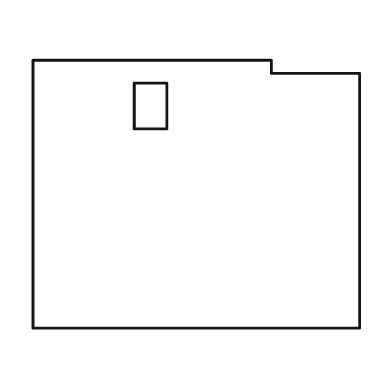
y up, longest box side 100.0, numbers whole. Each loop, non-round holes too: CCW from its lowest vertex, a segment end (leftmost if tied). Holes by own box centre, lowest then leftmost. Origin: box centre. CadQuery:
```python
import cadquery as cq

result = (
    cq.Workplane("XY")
    .moveTo(-50.0, -41.0)
    .lineTo(50.0, -41.0)
    .lineTo(50.0, 37.0)
    .lineTo(23.0, 37.0)
    .lineTo(23.0, 41.0)
    .lineTo(-50.0, 41.0)
    .close()
    .moveTo(-19.0, 20.0)
    .lineTo(-9.0, 20.0)
    .lineTo(-9.0, 34.0)
    .lineTo(-19.0, 34.0)
    .close()
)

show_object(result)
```